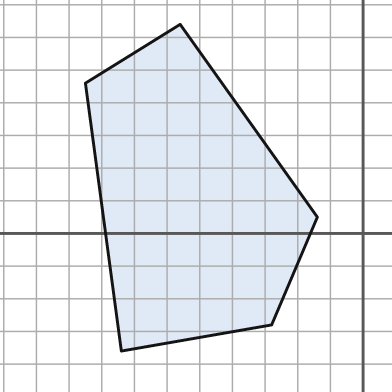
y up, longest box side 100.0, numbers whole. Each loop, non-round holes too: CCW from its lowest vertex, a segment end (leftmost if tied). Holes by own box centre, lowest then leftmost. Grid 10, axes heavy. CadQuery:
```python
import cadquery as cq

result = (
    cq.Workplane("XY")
    .moveTo(-74.0, -36.0)
    .lineTo(-28.0, -28.0)
    .lineTo(-14.0, 5.0)
    .lineTo(-56.0, 64.0)
    .lineTo(-85.0, 46.0)
    .close()
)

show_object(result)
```